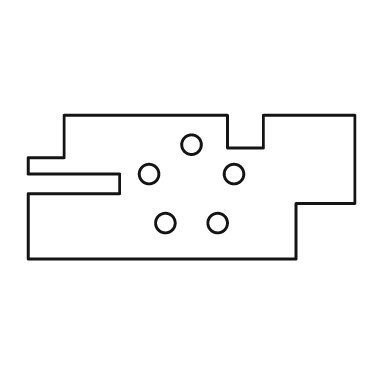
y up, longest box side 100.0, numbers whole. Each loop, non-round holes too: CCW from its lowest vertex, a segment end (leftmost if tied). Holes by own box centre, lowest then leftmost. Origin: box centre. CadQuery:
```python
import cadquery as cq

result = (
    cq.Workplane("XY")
    .moveTo(-50.0, -22.0)
    .lineTo(32.0, -22.0)
    .lineTo(32.0, -5.0)
    .lineTo(50.0, -5.0)
    .lineTo(50.0, 22.0)
    .lineTo(22.0, 22.0)
    .lineTo(22.0, 12.0)
    .lineTo(11.0, 12.0)
    .lineTo(11.0, 22.0)
    .lineTo(-39.0, 22.0)
    .lineTo(-39.0, 9.0)
    .lineTo(-50.0, 9.0)
    .lineTo(-50.0, 4.0)
    .lineTo(-22.0, 4.0)
    .lineTo(-22.0, -2.0)
    .lineTo(-50.0, -2.0)
    .close()
    .moveTo(-8.0, -11.0)
    .circle(3.0)
    .moveTo(8.0, -11.0)
    .circle(3.0)
    .moveTo(-13.0, 4.0)
    .circle(3.0)
    .moveTo(13.0, 4.0)
    .circle(3.0)
    .moveTo(0.0, 13.0)
    .circle(3.0)
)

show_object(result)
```